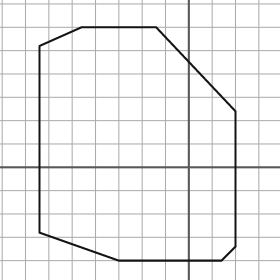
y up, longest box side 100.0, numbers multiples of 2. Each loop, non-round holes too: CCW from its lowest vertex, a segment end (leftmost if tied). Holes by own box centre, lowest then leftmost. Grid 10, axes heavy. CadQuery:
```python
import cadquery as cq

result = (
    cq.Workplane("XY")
    .moveTo(-30.0, -40.0)
    .lineTo(14.0, -40.0)
    .lineTo(20.0, -34.0)
    .lineTo(20.0, 24.0)
    .lineTo(-14.0, 60.0)
    .lineTo(-46.0, 60.0)
    .lineTo(-64.0, 52.0)
    .lineTo(-64.0, -28.0)
    .close()
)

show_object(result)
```